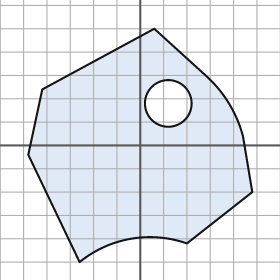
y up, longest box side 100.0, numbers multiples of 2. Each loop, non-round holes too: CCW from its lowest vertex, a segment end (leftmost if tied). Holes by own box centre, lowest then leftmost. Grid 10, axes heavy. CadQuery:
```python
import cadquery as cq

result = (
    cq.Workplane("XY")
    .moveTo(-26.0, -50.0)
    .threePointArc((-4.0, -40.0), (20.0, -42.0))
    .lineTo(48.0, -20.0)
    .lineTo(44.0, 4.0)
    .threePointArc((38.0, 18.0), (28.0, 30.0))
    .lineTo(6.0, 50.0)
    .lineTo(-42.0, 24.0)
    .lineTo(-48.0, -4.0)
    .close()
    .moveTo(12.0, 18.0)
    .circle(10.0)
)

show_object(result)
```